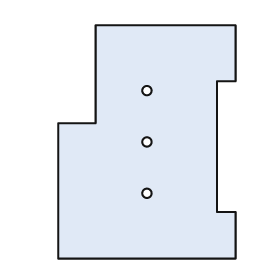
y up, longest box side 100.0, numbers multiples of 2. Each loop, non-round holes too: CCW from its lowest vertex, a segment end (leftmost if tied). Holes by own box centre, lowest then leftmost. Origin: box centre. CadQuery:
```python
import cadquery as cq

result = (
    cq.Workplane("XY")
    .moveTo(-38.0, -50.0)
    .lineTo(38.0, -50.0)
    .lineTo(38.0, -30.0)
    .lineTo(30.0, -30.0)
    .lineTo(30.0, 26.0)
    .lineTo(38.0, 26.0)
    .lineTo(38.0, 50.0)
    .lineTo(-22.0, 50.0)
    .lineTo(-22.0, 8.0)
    .lineTo(-38.0, 8.0)
    .close()
    .moveTo(0.0, -22.0)
    .circle(2.0)
    .moveTo(0.0, 0.0)
    .circle(2.0)
    .moveTo(0.0, 22.0)
    .circle(2.0)
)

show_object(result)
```